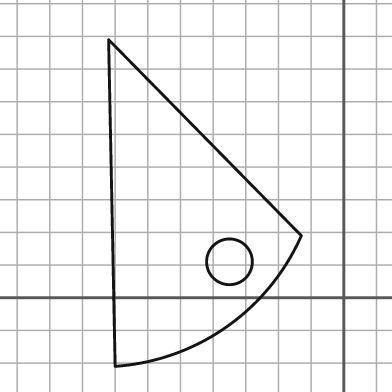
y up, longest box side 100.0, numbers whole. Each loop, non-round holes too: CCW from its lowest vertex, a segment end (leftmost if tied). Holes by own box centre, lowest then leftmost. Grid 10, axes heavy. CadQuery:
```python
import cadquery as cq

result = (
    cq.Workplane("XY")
    .moveTo(-70.0, -21.0)
    .threePointArc((-36.0, -9.0), (-13.0, 19.0))
    .lineTo(-72.0, 79.0)
    .close()
    .moveTo(-35.0, 11.0)
    .circle(7.0)
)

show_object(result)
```